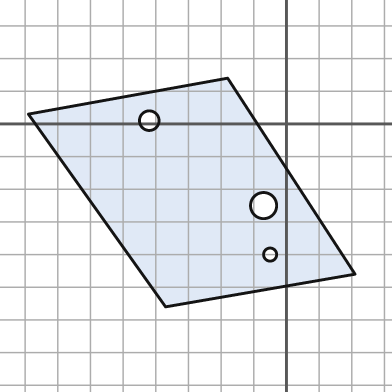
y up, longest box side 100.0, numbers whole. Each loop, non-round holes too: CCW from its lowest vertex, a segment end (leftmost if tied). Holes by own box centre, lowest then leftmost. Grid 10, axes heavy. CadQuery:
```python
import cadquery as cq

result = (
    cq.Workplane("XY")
    .moveTo(-37.0, -56.0)
    .lineTo(21.0, -46.0)
    .lineTo(-18.0, 14.0)
    .lineTo(-79.0, 3.0)
    .close()
    .moveTo(-5.0, -40.0)
    .circle(2.0)
    .moveTo(-7.0, -25.0)
    .circle(4.0)
    .moveTo(-42.0, 1.0)
    .circle(3.0)
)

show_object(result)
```